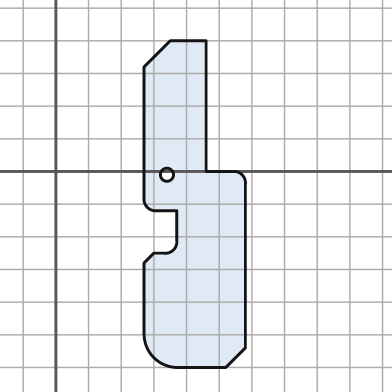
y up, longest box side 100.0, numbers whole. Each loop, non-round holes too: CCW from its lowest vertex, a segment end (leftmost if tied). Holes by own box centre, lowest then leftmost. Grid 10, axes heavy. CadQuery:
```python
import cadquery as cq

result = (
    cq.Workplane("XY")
    .moveTo(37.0, -60.0)
    .lineTo(52.0, -60.0)
    .lineTo(58.0, -54.0)
    .lineTo(58.0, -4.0)
    .threePointArc((57.0, -1.0), (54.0, 0.0))
    .lineTo(46.0, 0.0)
    .lineTo(46.0, 40.0)
    .lineTo(35.0, 40.0)
    .lineTo(27.0, 32.0)
    .lineTo(27.0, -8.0)
    .threePointArc((28.0, -11.0), (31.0, -12.0))
    .lineTo(37.0, -12.0)
    .lineTo(37.0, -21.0)
    .threePointArc((36.0, -24.0), (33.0, -25.0))
    .lineTo(30.0, -25.0)
    .lineTo(27.0, -28.0)
    .lineTo(27.0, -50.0)
    .threePointArc((30.0, -57.0), (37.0, -60.0))
    .close()
    .moveTo(34.0, -1.0)
    .circle(2.0)
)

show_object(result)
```